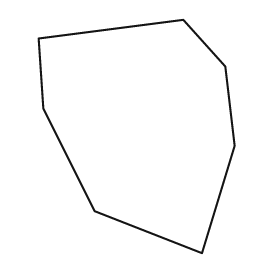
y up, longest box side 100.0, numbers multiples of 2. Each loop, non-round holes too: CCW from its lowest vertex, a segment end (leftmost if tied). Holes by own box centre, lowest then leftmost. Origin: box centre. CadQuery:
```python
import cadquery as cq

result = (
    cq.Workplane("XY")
    .moveTo(28.0, -50.0)
    .lineTo(42.0, -4.0)
    .lineTo(38.0, 30.0)
    .lineTo(20.0, 50.0)
    .lineTo(-42.0, 42.0)
    .lineTo(-40.0, 12.0)
    .lineTo(-18.0, -32.0)
    .close()
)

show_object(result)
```